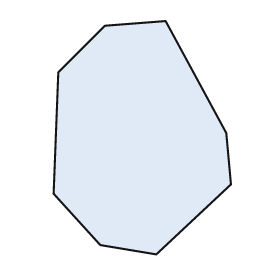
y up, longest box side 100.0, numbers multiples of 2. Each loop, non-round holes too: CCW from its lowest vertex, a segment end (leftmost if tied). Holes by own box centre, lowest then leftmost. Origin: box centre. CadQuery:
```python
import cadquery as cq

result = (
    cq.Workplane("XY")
    .moveTo(6.0, -50.0)
    .lineTo(38.0, -20.0)
    .lineTo(36.0, 2.0)
    .lineTo(10.0, 50.0)
    .lineTo(-16.0, 48.0)
    .lineTo(-36.0, 28.0)
    .lineTo(-38.0, -24.0)
    .lineTo(-18.0, -46.0)
    .close()
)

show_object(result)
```